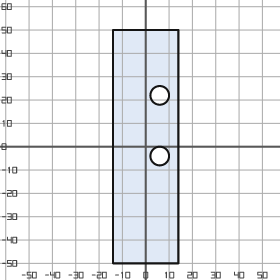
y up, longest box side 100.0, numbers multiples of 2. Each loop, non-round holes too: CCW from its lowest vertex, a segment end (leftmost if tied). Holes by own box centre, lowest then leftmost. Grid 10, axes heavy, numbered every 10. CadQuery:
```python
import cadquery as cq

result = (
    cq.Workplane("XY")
    .moveTo(-14.0, -50.0)
    .lineTo(14.0, -50.0)
    .lineTo(14.0, 50.0)
    .lineTo(-14.0, 50.0)
    .close()
    .moveTo(6.0, -4.0)
    .circle(4.0)
    .moveTo(6.0, 22.0)
    .circle(4.0)
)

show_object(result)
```